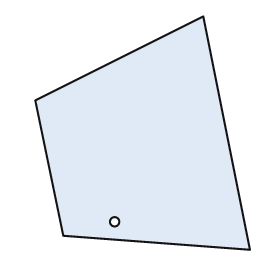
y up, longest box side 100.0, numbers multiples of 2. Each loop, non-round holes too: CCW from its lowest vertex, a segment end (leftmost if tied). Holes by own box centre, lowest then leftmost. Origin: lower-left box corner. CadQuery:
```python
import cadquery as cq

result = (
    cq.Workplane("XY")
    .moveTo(92.0, 0.0)
    .lineTo(72.0, 100.0)
    .lineTo(0.0, 64.0)
    .lineTo(12.0, 6.0)
    .close()
    .moveTo(34.0, 12.0)
    .circle(2.0)
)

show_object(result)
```